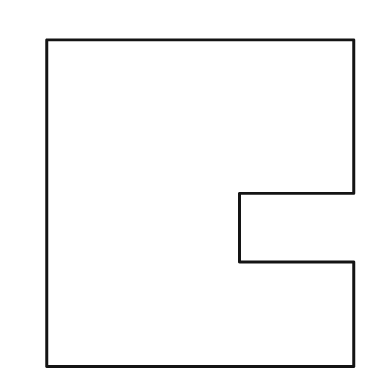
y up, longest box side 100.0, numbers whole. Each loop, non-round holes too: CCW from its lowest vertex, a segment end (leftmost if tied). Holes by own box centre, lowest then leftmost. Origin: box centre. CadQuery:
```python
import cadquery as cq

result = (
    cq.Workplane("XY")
    .moveTo(-47.0, -50.0)
    .lineTo(47.0, -50.0)
    .lineTo(47.0, -18.0)
    .lineTo(12.0, -18.0)
    .lineTo(12.0, 3.0)
    .lineTo(47.0, 3.0)
    .lineTo(47.0, 50.0)
    .lineTo(-47.0, 50.0)
    .close()
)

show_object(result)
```